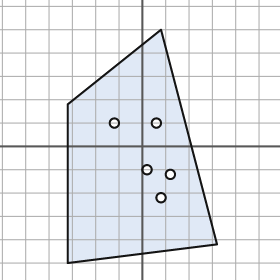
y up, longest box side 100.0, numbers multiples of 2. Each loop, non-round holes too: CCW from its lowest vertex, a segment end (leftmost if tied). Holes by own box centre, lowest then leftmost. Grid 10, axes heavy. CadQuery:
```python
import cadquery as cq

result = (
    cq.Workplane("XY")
    .moveTo(-32.0, -50.0)
    .lineTo(32.0, -42.0)
    .lineTo(8.0, 50.0)
    .lineTo(-32.0, 18.0)
    .close()
    .moveTo(8.0, -22.0)
    .circle(2.0)
    .moveTo(12.0, -12.0)
    .circle(2.0)
    .moveTo(2.0, -10.0)
    .circle(2.0)
    .moveTo(-12.0, 10.0)
    .circle(2.0)
    .moveTo(6.0, 10.0)
    .circle(2.0)
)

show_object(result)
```